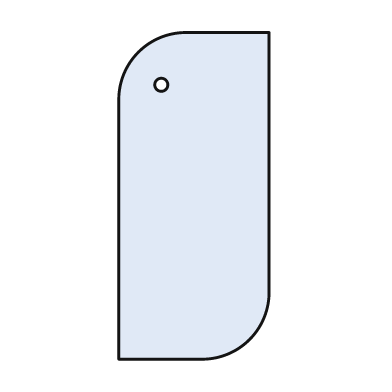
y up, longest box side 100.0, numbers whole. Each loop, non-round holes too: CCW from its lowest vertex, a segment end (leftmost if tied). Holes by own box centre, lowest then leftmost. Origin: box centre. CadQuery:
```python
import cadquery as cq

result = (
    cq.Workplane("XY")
    .moveTo(-23.0, -50.0)
    .lineTo(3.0, -50.0)
    .threePointArc((17.0, -44.0), (23.0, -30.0))
    .lineTo(23.0, 50.0)
    .lineTo(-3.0, 50.0)
    .threePointArc((-17.0, 44.0), (-23.0, 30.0))
    .close()
    .moveTo(-10.0, 34.0)
    .circle(2.0)
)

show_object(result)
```